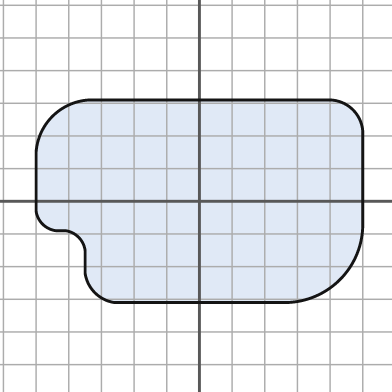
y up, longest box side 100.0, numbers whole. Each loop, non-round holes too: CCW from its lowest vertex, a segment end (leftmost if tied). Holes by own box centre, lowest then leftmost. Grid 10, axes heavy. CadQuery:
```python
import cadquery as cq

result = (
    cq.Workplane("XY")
    .moveTo(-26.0, -31.0)
    .lineTo(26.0, -31.0)
    .threePointArc((43.0, -24.0), (50.0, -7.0))
    .lineTo(50.0, 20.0)
    .threePointArc((47.0, 28.0), (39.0, 31.0))
    .lineTo(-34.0, 31.0)
    .threePointArc((-45.0, 26.0), (-50.0, 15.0))
    .lineTo(-50.0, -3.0)
    .threePointArc((-48.0, -7.0), (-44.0, -9.0))
    .lineTo(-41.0, -9.0)
    .threePointArc((-37.0, -11.0), (-35.0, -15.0))
    .lineTo(-35.0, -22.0)
    .threePointArc((-32.0, -28.0), (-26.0, -31.0))
    .close()
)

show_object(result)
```